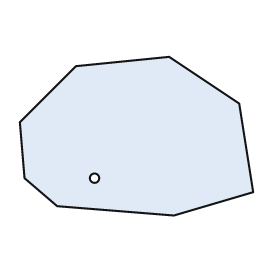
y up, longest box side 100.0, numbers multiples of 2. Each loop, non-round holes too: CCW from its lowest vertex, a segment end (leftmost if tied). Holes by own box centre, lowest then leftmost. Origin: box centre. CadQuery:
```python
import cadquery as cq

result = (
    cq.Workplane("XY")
    .moveTo(16.0, -34.0)
    .lineTo(50.0, -24.0)
    .lineTo(44.0, 14.0)
    .lineTo(14.0, 34.0)
    .lineTo(-26.0, 30.0)
    .lineTo(-50.0, 6.0)
    .lineTo(-48.0, -18.0)
    .lineTo(-34.0, -30.0)
    .close()
    .moveTo(-18.0, -18.0)
    .circle(2.0)
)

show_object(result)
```